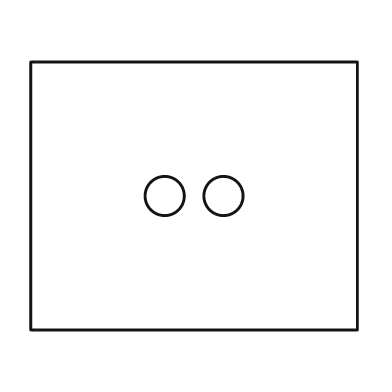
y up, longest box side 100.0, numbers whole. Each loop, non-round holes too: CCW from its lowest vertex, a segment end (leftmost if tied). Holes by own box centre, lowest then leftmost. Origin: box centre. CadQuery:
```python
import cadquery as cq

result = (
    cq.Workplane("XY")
    .moveTo(-50.0, -41.0)
    .lineTo(50.0, -41.0)
    .lineTo(50.0, 41.0)
    .lineTo(-50.0, 41.0)
    .close()
    .moveTo(-9.0, 0.0)
    .circle(6.0)
    .moveTo(9.0, 0.0)
    .circle(6.0)
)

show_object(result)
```